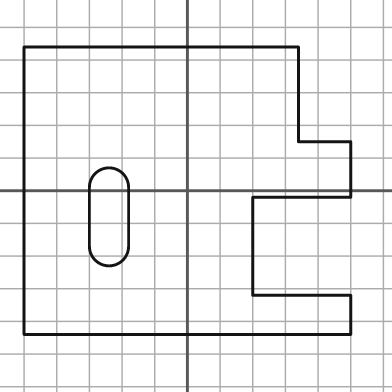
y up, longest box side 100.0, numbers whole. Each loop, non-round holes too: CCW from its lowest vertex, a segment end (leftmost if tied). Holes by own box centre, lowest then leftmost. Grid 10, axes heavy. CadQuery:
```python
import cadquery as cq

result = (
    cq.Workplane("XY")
    .moveTo(-50.0, -44.0)
    .lineTo(50.0, -44.0)
    .lineTo(50.0, -32.0)
    .lineTo(20.0, -32.0)
    .lineTo(20.0, -2.0)
    .lineTo(50.0, -2.0)
    .lineTo(50.0, 15.0)
    .lineTo(34.0, 15.0)
    .lineTo(34.0, 44.0)
    .lineTo(-50.0, 44.0)
    .close()
    .moveTo(-30.0, -17.0)
    .threePointArc((-24.0, -23.0), (-18.0, -17.0))
    .lineTo(-18.0, 1.0)
    .threePointArc((-24.0, 7.0), (-30.0, 1.0))
    .close()
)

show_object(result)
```